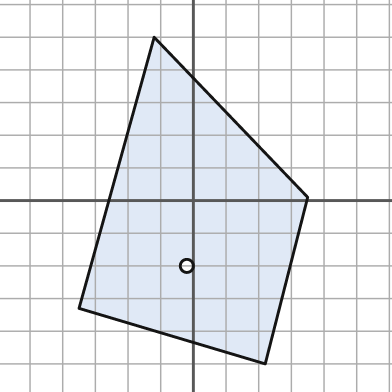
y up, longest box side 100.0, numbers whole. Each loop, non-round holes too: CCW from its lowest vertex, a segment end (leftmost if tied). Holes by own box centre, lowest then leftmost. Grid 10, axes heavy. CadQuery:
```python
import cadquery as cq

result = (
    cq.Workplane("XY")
    .moveTo(22.0, -50.0)
    .lineTo(35.0, 1.0)
    .lineTo(-12.0, 50.0)
    .lineTo(-35.0, -33.0)
    .close()
    .moveTo(-2.0, -20.0)
    .circle(2.0)
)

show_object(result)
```